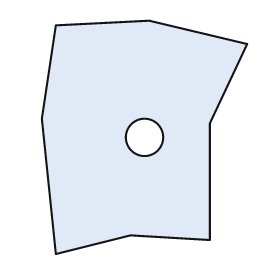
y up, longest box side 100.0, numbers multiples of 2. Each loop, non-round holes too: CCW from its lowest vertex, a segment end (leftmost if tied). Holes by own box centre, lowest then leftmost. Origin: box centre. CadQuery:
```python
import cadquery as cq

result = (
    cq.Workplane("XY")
    .moveTo(-38.0, -50.0)
    .lineTo(-6.0, -42.0)
    .lineTo(28.0, -44.0)
    .lineTo(28.0, 6.0)
    .lineTo(44.0, 40.0)
    .lineTo(2.0, 50.0)
    .lineTo(-38.0, 48.0)
    .lineTo(-44.0, 8.0)
    .close()
    .moveTo(0.0, 0.0)
    .circle(8.0)
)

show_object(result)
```